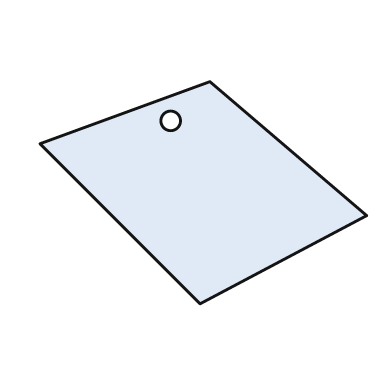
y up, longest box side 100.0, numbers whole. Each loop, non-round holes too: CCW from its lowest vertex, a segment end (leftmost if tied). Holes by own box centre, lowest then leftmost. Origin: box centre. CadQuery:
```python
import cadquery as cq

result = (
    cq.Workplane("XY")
    .moveTo(-1.0, -34.0)
    .lineTo(50.0, -7.0)
    .lineTo(2.0, 34.0)
    .lineTo(-50.0, 15.0)
    .close()
    .moveTo(-10.0, 22.0)
    .circle(3.0)
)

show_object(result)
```